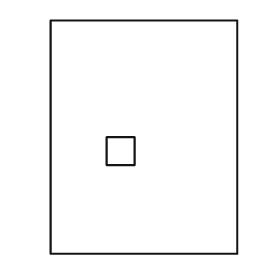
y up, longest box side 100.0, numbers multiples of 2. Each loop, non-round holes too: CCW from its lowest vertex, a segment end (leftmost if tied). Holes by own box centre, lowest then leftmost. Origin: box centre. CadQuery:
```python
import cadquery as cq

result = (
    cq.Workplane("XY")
    .moveTo(-40.0, -50.0)
    .lineTo(40.0, -50.0)
    .lineTo(40.0, 50.0)
    .lineTo(-40.0, 50.0)
    .close()
    .moveTo(-16.0, -12.0)
    .lineTo(-4.0, -12.0)
    .lineTo(-4.0, 0.0)
    .lineTo(-16.0, 0.0)
    .close()
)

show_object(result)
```